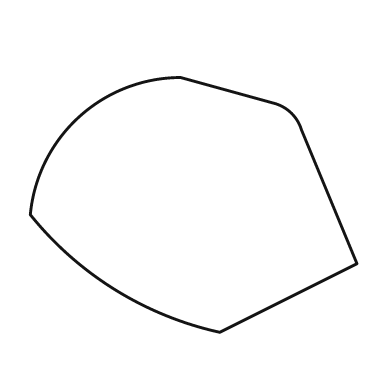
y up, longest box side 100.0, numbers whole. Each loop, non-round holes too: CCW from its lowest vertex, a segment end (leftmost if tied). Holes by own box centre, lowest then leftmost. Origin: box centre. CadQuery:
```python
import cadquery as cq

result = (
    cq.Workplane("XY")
    .moveTo(8.0, -39.0)
    .lineTo(50.0, -18.0)
    .lineTo(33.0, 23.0)
    .threePointArc((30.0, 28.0), (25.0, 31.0))
    .lineTo(-4.0, 39.0)
    .threePointArc((-35.0, 27.0), (-50.0, -3.0))
    .threePointArc((-24.0, -26.0), (8.0, -39.0))
    .close()
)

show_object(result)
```